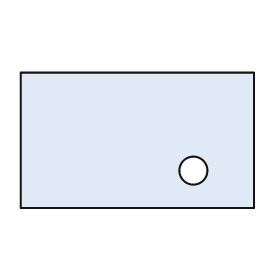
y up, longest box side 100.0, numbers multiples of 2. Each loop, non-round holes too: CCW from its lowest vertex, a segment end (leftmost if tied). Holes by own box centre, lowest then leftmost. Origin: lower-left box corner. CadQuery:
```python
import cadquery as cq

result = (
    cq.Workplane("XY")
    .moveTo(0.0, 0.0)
    .lineTo(100.0, 0.0)
    .lineTo(100.0, 58.0)
    .lineTo(0.0, 58.0)
    .close()
    .moveTo(74.0, 16.0)
    .circle(6.0)
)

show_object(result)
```